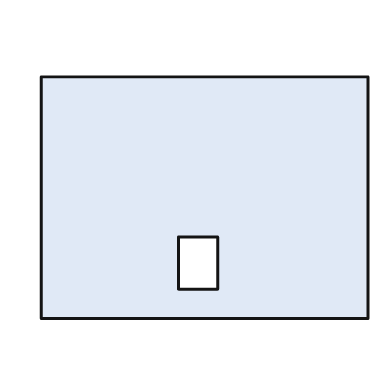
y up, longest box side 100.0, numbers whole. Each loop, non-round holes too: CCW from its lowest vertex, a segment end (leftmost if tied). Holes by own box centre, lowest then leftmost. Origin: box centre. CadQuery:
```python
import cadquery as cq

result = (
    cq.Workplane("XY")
    .moveTo(-50.0, -37.0)
    .lineTo(50.0, -37.0)
    .lineTo(50.0, 37.0)
    .lineTo(-50.0, 37.0)
    .close()
    .moveTo(-8.0, -28.0)
    .lineTo(4.0, -28.0)
    .lineTo(4.0, -12.0)
    .lineTo(-8.0, -12.0)
    .close()
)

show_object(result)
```